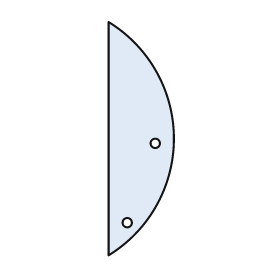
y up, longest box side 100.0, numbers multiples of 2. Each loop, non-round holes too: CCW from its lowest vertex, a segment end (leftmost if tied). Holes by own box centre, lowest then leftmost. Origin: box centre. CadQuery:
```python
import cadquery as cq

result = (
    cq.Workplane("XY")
    .moveTo(-14.0, -50.0)
    .threePointArc((14.0, 0.0), (-14.0, 50.0))
    .close()
    .moveTo(-6.0, -36.0)
    .circle(2.0)
    .moveTo(6.0, -2.0)
    .circle(2.0)
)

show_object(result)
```